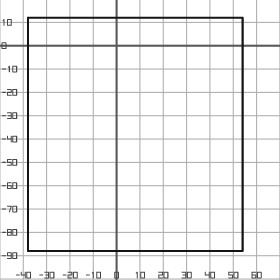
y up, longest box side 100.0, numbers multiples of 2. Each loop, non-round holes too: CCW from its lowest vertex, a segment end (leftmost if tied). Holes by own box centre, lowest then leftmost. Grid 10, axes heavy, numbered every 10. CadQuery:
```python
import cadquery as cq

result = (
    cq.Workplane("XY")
    .moveTo(-38.0, -88.0)
    .lineTo(54.0, -88.0)
    .lineTo(54.0, 12.0)
    .lineTo(-38.0, 12.0)
    .close()
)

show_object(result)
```